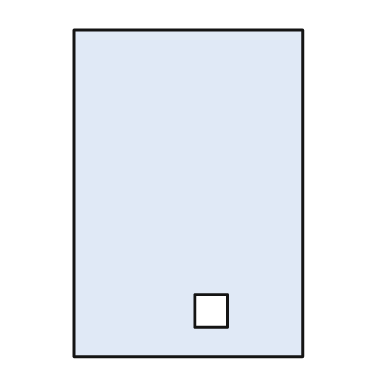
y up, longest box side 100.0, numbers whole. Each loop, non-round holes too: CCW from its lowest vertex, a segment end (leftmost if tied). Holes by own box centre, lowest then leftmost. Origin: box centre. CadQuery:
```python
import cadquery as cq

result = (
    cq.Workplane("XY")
    .moveTo(-35.0, -50.0)
    .lineTo(35.0, -50.0)
    .lineTo(35.0, 50.0)
    .lineTo(-35.0, 50.0)
    .close()
    .moveTo(2.0, -41.0)
    .lineTo(12.0, -41.0)
    .lineTo(12.0, -31.0)
    .lineTo(2.0, -31.0)
    .close()
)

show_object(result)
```